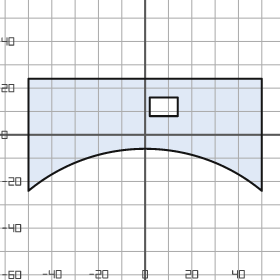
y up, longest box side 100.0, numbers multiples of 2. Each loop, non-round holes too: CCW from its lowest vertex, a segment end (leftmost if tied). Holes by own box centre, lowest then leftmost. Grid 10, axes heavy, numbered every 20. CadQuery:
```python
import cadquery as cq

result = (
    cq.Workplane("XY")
    .moveTo(-50.0, -24.0)
    .threePointArc((0.0, -6.0), (50.0, -24.0))
    .lineTo(50.0, 24.0)
    .lineTo(-50.0, 24.0)
    .close()
    .moveTo(2.0, 8.0)
    .lineTo(14.0, 8.0)
    .lineTo(14.0, 16.0)
    .lineTo(2.0, 16.0)
    .close()
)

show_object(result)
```